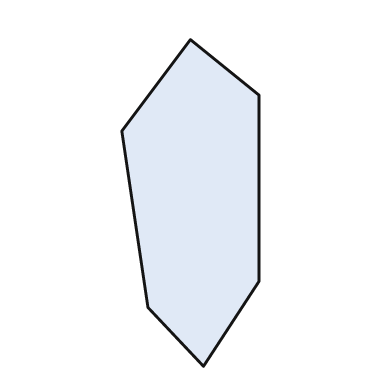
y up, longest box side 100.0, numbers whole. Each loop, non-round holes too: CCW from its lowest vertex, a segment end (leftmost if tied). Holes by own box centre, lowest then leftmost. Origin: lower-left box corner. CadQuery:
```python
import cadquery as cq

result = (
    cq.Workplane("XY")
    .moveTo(25.0, 0.0)
    .lineTo(42.0, 26.0)
    .lineTo(42.0, 83.0)
    .lineTo(21.0, 100.0)
    .lineTo(0.0, 72.0)
    .lineTo(8.0, 18.0)
    .close()
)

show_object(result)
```